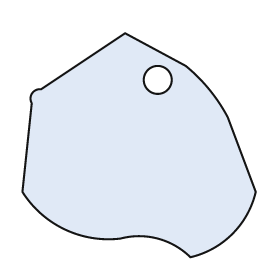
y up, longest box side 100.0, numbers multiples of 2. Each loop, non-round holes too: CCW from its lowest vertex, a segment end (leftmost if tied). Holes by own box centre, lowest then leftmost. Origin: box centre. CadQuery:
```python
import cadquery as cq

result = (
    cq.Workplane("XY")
    .moveTo(22.0, -48.0)
    .threePointArc((40.0, -38.0), (50.0, -20.0))
    .lineTo(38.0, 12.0)
    .threePointArc((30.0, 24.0), (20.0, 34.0))
    .lineTo(-6.0, 48.0)
    .lineTo(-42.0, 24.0)
    .threePointArc((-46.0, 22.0), (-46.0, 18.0))
    .lineTo(-50.0, -20.0)
    .threePointArc((-32.0, -36.0), (-8.0, -40.0))
    .threePointArc((8.0, -40.0), (22.0, -48.0))
    .close()
    .moveTo(8.0, 28.0)
    .circle(6.0)
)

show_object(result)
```